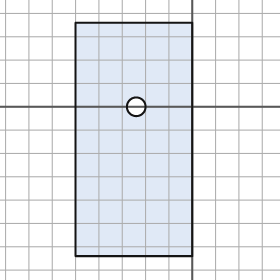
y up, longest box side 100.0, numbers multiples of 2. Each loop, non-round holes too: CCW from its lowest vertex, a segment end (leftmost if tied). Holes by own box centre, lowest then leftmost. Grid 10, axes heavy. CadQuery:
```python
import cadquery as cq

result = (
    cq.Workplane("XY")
    .moveTo(-50.0, -64.0)
    .lineTo(0.0, -64.0)
    .lineTo(0.0, 36.0)
    .lineTo(-50.0, 36.0)
    .close()
    .moveTo(-24.0, 0.0)
    .circle(4.0)
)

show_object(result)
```